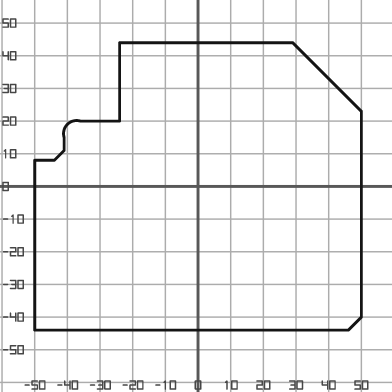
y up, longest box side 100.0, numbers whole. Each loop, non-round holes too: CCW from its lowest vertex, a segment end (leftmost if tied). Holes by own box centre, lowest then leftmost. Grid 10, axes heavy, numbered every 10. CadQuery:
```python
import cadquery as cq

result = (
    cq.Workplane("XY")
    .moveTo(-50.0, -44.0)
    .lineTo(46.0, -44.0)
    .lineTo(50.0, -40.0)
    .lineTo(50.0, 23.0)
    .lineTo(29.0, 44.0)
    .lineTo(-24.0, 44.0)
    .lineTo(-24.0, 20.0)
    .lineTo(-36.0, 20.0)
    .threePointArc((-40.0, 19.0), (-41.0, 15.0))
    .lineTo(-41.0, 11.0)
    .lineTo(-44.0, 8.0)
    .lineTo(-50.0, 8.0)
    .close()
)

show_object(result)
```